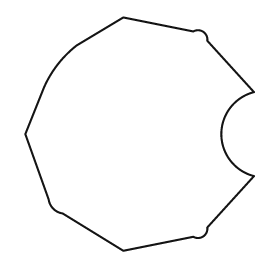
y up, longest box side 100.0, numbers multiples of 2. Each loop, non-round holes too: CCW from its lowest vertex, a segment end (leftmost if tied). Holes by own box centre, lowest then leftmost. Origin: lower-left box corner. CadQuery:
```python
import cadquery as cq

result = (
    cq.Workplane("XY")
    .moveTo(42.0, 0.0)
    .lineTo(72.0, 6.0)
    .threePointArc((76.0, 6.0), (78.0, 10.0))
    .lineTo(98.0, 32.0)
    .threePointArc((84.0, 50.0), (98.0, 68.0))
    .lineTo(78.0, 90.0)
    .threePointArc((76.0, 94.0), (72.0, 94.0))
    .lineTo(42.0, 100.0)
    .lineTo(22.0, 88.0)
    .threePointArc((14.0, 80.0), (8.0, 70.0))
    .lineTo(0.0, 50.0)
    .lineTo(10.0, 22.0)
    .threePointArc((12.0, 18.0), (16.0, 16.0))
    .close()
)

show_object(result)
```